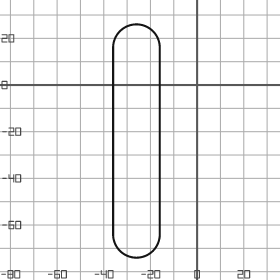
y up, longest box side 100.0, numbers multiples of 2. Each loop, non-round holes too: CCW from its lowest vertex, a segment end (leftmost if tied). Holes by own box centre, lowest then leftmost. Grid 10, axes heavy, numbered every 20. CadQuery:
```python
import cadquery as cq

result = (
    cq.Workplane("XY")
    .moveTo(-36.0, -64.0)
    .threePointArc((-26.0, -74.0), (-16.0, -64.0))
    .lineTo(-16.0, 16.0)
    .threePointArc((-26.0, 26.0), (-36.0, 16.0))
    .close()
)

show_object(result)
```